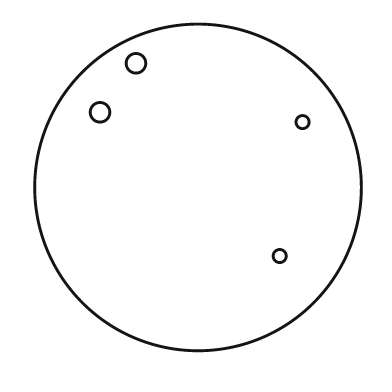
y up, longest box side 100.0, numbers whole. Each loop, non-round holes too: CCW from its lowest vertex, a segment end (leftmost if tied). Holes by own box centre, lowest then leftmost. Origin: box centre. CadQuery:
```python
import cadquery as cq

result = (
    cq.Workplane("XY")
    .moveTo(0.0, 0.0)
    .circle(50.0)
    .moveTo(25.0, -21.0)
    .circle(2.0)
    .moveTo(32.0, 20.0)
    .circle(2.0)
    .moveTo(-30.0, 23.0)
    .circle(3.0)
    .moveTo(-19.0, 38.0)
    .circle(3.0)
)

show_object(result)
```